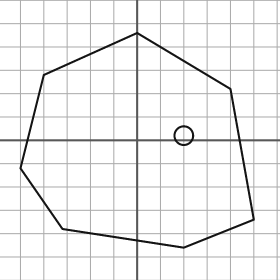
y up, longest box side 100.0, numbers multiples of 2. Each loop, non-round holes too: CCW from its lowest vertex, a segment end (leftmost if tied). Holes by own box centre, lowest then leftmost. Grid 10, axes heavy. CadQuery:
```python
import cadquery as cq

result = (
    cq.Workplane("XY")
    .moveTo(20.0, -46.0)
    .lineTo(50.0, -34.0)
    .lineTo(40.0, 22.0)
    .lineTo(0.0, 46.0)
    .lineTo(-40.0, 28.0)
    .lineTo(-50.0, -12.0)
    .lineTo(-32.0, -38.0)
    .close()
    .moveTo(20.0, 2.0)
    .circle(4.0)
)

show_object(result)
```